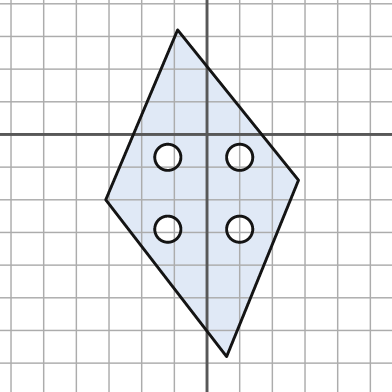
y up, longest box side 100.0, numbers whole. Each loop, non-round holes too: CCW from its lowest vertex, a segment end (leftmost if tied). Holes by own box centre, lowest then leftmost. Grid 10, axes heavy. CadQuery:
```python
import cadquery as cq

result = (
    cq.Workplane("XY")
    .moveTo(6.0, -68.0)
    .lineTo(28.0, -14.0)
    .lineTo(-9.0, 32.0)
    .lineTo(-31.0, -20.0)
    .close()
    .moveTo(-12.0, -29.0)
    .circle(4.0)
    .moveTo(10.0, -29.0)
    .circle(4.0)
    .moveTo(-12.0, -7.0)
    .circle(4.0)
    .moveTo(10.0, -7.0)
    .circle(4.0)
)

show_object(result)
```